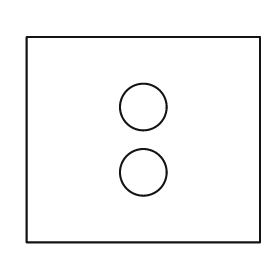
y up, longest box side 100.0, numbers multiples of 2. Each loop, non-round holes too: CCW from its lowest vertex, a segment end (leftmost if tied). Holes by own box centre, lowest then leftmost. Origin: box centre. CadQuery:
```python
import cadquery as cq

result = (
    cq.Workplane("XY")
    .moveTo(-50.0, -44.0)
    .lineTo(50.0, -44.0)
    .lineTo(50.0, 44.0)
    .lineTo(-50.0, 44.0)
    .close()
    .moveTo(0.0, -14.0)
    .circle(10.0)
    .moveTo(0.0, 14.0)
    .circle(10.0)
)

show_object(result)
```